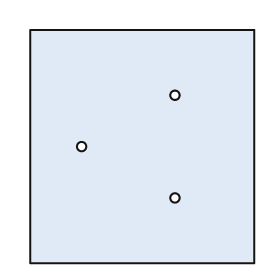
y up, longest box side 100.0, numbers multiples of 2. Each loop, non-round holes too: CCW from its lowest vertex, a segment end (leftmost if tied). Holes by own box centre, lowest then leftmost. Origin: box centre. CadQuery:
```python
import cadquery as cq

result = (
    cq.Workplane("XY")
    .moveTo(-48.0, -50.0)
    .lineTo(48.0, -50.0)
    .lineTo(48.0, 50.0)
    .lineTo(-48.0, 50.0)
    .close()
    .moveTo(14.0, -22.0)
    .circle(2.0)
    .moveTo(-26.0, 0.0)
    .circle(2.0)
    .moveTo(14.0, 22.0)
    .circle(2.0)
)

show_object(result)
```